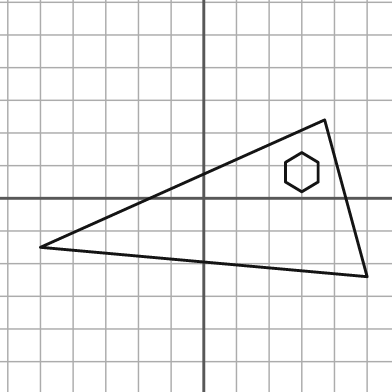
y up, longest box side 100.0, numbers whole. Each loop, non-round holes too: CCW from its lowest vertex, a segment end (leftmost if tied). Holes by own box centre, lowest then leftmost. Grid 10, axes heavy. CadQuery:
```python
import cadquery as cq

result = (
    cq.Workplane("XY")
    .moveTo(50.0, -24.0)
    .lineTo(37.0, 24.0)
    .lineTo(-50.0, -15.0)
    .close()
    .moveTo(30.0, 2.0)
    .lineTo(35.0, 5.0)
    .lineTo(35.0, 11.0)
    .lineTo(30.0, 14.0)
    .lineTo(25.0, 11.0)
    .lineTo(25.0, 5.0)
    .close()
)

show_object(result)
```